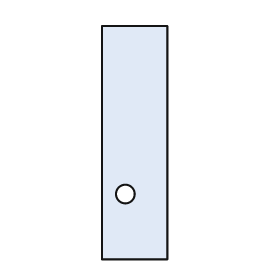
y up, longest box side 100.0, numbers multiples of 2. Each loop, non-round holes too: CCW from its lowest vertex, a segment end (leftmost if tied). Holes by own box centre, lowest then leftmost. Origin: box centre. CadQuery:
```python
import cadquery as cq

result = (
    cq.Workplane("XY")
    .moveTo(-14.0, -50.0)
    .lineTo(14.0, -50.0)
    .lineTo(14.0, 50.0)
    .lineTo(-14.0, 50.0)
    .close()
    .moveTo(-4.0, -22.0)
    .circle(4.0)
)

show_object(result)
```